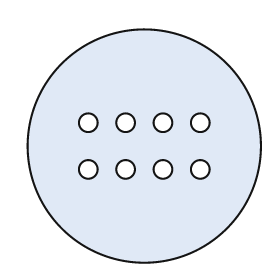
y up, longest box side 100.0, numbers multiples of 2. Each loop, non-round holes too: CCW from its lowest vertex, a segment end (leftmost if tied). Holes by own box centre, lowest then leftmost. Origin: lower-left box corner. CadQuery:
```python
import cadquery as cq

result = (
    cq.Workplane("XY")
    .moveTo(50.0, 50.0)
    .circle(50.0)
    .moveTo(26.0, 40.0)
    .circle(4.0)
    .moveTo(42.0, 40.0)
    .circle(4.0)
    .moveTo(58.0, 40.0)
    .circle(4.0)
    .moveTo(74.0, 40.0)
    .circle(4.0)
    .moveTo(26.0, 60.0)
    .circle(4.0)
    .moveTo(42.0, 60.0)
    .circle(4.0)
    .moveTo(58.0, 60.0)
    .circle(4.0)
    .moveTo(74.0, 60.0)
    .circle(4.0)
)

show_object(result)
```